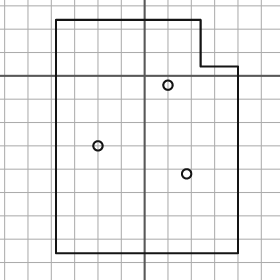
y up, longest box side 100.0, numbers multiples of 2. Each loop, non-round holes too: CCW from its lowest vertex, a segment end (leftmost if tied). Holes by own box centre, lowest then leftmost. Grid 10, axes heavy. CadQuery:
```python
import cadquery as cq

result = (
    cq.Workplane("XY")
    .moveTo(-38.0, -76.0)
    .lineTo(40.0, -76.0)
    .lineTo(40.0, 4.0)
    .lineTo(24.0, 4.0)
    .lineTo(24.0, 24.0)
    .lineTo(-38.0, 24.0)
    .close()
    .moveTo(18.0, -42.0)
    .circle(2.0)
    .moveTo(-20.0, -30.0)
    .circle(2.0)
    .moveTo(10.0, -4.0)
    .circle(2.0)
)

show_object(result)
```